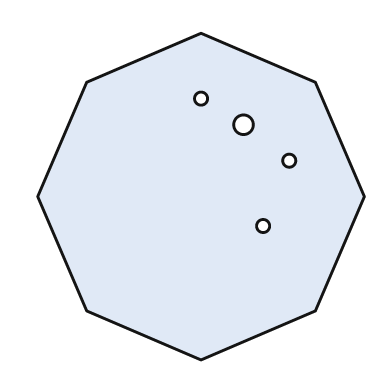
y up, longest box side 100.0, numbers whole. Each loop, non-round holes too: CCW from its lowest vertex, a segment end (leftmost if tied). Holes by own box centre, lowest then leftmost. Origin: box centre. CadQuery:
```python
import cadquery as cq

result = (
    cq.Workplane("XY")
    .moveTo(0.0, -50.0)
    .lineTo(35.0, -35.0)
    .lineTo(50.0, 0.0)
    .lineTo(35.0, 35.0)
    .lineTo(0.0, 50.0)
    .lineTo(-35.0, 35.0)
    .lineTo(-50.0, 0.0)
    .lineTo(-35.0, -35.0)
    .close()
    .moveTo(19.0, -9.0)
    .circle(2.0)
    .moveTo(27.0, 11.0)
    .circle(2.0)
    .moveTo(13.0, 22.0)
    .circle(3.0)
    .moveTo(0.0, 30.0)
    .circle(2.0)
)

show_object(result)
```